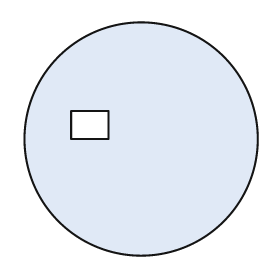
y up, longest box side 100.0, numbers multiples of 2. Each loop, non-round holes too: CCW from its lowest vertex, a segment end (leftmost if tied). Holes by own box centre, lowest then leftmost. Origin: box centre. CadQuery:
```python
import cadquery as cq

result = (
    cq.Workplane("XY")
    .moveTo(0.0, 0.0)
    .circle(50.0)
    .moveTo(-30.0, 0.0)
    .lineTo(-14.0, 0.0)
    .lineTo(-14.0, 12.0)
    .lineTo(-30.0, 12.0)
    .close()
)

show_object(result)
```